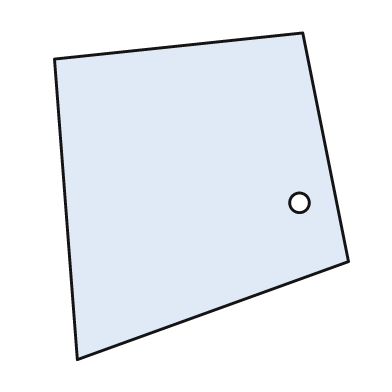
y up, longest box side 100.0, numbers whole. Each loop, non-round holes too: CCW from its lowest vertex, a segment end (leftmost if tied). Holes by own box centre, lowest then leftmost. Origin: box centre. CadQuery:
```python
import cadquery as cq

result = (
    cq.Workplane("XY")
    .moveTo(-38.0, -50.0)
    .lineTo(45.0, -20.0)
    .lineTo(31.0, 50.0)
    .lineTo(-45.0, 42.0)
    .close()
    .moveTo(30.0, -2.0)
    .circle(3.0)
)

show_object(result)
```